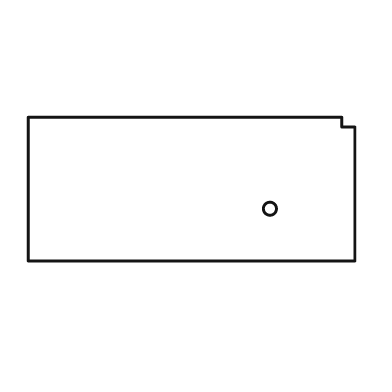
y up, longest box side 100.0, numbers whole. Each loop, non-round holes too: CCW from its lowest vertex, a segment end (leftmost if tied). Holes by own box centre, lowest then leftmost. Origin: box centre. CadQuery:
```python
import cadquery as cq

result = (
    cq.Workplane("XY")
    .moveTo(-50.0, -22.0)
    .lineTo(50.0, -22.0)
    .lineTo(50.0, 19.0)
    .lineTo(46.0, 19.0)
    .lineTo(46.0, 22.0)
    .lineTo(-50.0, 22.0)
    .close()
    .moveTo(24.0, -6.0)
    .circle(2.0)
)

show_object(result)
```